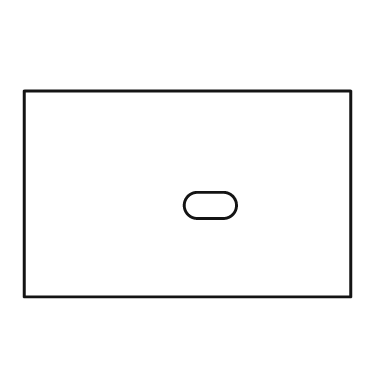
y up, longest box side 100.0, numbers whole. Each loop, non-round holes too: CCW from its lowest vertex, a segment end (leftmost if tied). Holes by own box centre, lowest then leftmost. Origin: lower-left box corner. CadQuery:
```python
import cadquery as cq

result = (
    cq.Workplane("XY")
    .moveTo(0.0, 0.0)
    .lineTo(100.0, 0.0)
    .lineTo(100.0, 63.0)
    .lineTo(0.0, 63.0)
    .close()
    .moveTo(53.0, 24.0)
    .lineTo(61.0, 24.0)
    .threePointArc((65.0, 28.0), (61.0, 32.0))
    .lineTo(53.0, 32.0)
    .threePointArc((49.0, 28.0), (53.0, 24.0))
    .close()
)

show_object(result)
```